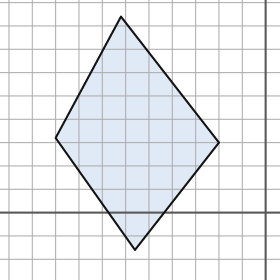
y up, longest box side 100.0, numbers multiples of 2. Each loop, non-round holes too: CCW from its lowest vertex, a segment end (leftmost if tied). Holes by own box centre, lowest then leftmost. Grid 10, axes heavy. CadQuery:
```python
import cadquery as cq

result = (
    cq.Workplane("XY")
    .moveTo(-56.0, -16.0)
    .lineTo(-20.0, 30.0)
    .lineTo(-62.0, 84.0)
    .lineTo(-90.0, 32.0)
    .close()
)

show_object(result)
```